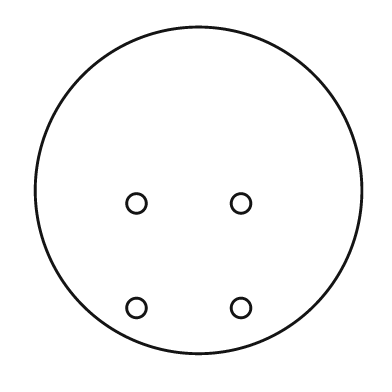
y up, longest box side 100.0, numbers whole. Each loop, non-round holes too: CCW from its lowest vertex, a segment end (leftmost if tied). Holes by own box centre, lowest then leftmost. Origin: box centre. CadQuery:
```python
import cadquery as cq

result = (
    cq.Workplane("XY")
    .moveTo(0.0, 0.0)
    .circle(50.0)
    .moveTo(-19.0, -36.0)
    .circle(3.0)
    .moveTo(13.0, -36.0)
    .circle(3.0)
    .moveTo(-19.0, -4.0)
    .circle(3.0)
    .moveTo(13.0, -4.0)
    .circle(3.0)
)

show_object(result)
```